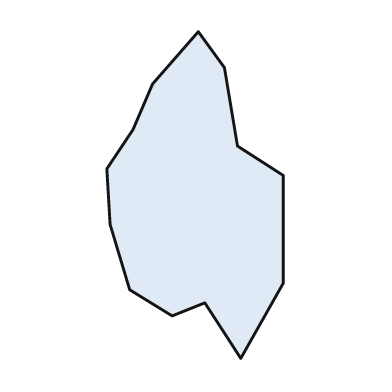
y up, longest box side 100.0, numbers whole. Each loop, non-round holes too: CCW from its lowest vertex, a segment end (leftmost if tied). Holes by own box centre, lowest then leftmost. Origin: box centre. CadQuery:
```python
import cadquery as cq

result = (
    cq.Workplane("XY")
    .moveTo(14.0, -50.0)
    .lineTo(27.0, -27.0)
    .lineTo(27.0, 6.0)
    .lineTo(13.0, 15.0)
    .lineTo(9.0, 39.0)
    .lineTo(1.0, 50.0)
    .lineTo(-13.0, 34.0)
    .lineTo(-19.0, 20.0)
    .lineTo(-27.0, 8.0)
    .lineTo(-26.0, -9.0)
    .lineTo(-20.0, -29.0)
    .lineTo(-7.0, -37.0)
    .lineTo(3.0, -33.0)
    .close()
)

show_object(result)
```